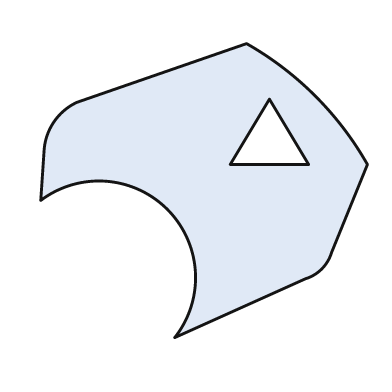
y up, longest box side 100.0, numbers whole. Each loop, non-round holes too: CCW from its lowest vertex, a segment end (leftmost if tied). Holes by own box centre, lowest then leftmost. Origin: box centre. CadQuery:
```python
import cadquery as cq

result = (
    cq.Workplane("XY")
    .moveTo(-9.0, -45.0)
    .lineTo(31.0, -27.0)
    .threePointArc((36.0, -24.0), (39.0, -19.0))
    .lineTo(50.0, 8.0)
    .threePointArc((34.0, 29.0), (13.0, 45.0))
    .lineTo(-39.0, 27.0)
    .threePointArc((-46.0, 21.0), (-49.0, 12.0))
    .lineTo(-50.0, -3.0)
    .threePointArc((-11.0, -6.0), (-9.0, -45.0))
    .close()
    .moveTo(8.0, 8.0)
    .lineTo(32.0, 8.0)
    .lineTo(20.0, 28.0)
    .close()
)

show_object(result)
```